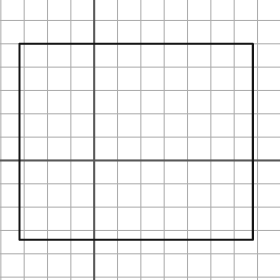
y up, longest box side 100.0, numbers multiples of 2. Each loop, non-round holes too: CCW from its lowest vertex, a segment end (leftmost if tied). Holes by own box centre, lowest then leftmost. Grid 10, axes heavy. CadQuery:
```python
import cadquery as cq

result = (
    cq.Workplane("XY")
    .moveTo(-32.0, -34.0)
    .lineTo(68.0, -34.0)
    .lineTo(68.0, 50.0)
    .lineTo(-32.0, 50.0)
    .close()
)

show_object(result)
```